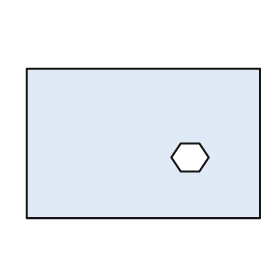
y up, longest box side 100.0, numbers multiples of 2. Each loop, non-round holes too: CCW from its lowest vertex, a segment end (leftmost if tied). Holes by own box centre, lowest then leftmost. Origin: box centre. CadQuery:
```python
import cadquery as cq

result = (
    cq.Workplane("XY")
    .moveTo(-50.0, -32.0)
    .lineTo(50.0, -32.0)
    .lineTo(50.0, 32.0)
    .lineTo(-50.0, 32.0)
    .close()
    .moveTo(16.0, -12.0)
    .lineTo(24.0, -12.0)
    .lineTo(28.0, -6.0)
    .lineTo(24.0, 0.0)
    .lineTo(16.0, 0.0)
    .lineTo(12.0, -6.0)
    .close()
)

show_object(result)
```